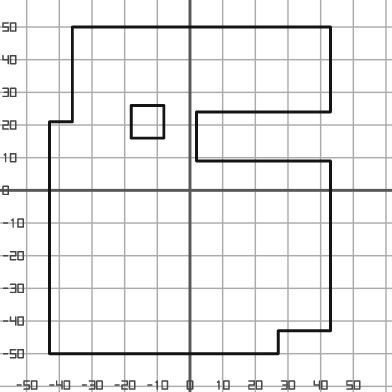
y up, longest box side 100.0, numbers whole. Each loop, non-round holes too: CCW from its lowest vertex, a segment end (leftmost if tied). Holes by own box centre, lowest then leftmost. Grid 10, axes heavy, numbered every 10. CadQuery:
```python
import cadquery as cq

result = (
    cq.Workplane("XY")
    .moveTo(-43.0, -50.0)
    .lineTo(27.0, -50.0)
    .lineTo(27.0, -43.0)
    .lineTo(43.0, -43.0)
    .lineTo(43.0, 9.0)
    .lineTo(2.0, 9.0)
    .lineTo(2.0, 24.0)
    .lineTo(43.0, 24.0)
    .lineTo(43.0, 50.0)
    .lineTo(-36.0, 50.0)
    .lineTo(-36.0, 21.0)
    .lineTo(-43.0, 21.0)
    .close()
    .moveTo(-18.0, 16.0)
    .lineTo(-8.0, 16.0)
    .lineTo(-8.0, 26.0)
    .lineTo(-18.0, 26.0)
    .close()
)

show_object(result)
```